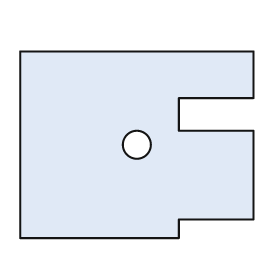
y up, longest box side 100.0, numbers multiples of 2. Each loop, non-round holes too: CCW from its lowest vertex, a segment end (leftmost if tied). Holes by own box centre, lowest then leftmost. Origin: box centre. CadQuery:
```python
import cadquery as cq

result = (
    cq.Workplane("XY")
    .moveTo(-50.0, -40.0)
    .lineTo(18.0, -40.0)
    .lineTo(18.0, -32.0)
    .lineTo(50.0, -32.0)
    .lineTo(50.0, 6.0)
    .lineTo(18.0, 6.0)
    .lineTo(18.0, 20.0)
    .lineTo(50.0, 20.0)
    .lineTo(50.0, 40.0)
    .lineTo(-50.0, 40.0)
    .close()
    .moveTo(0.0, 0.0)
    .circle(6.0)
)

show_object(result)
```